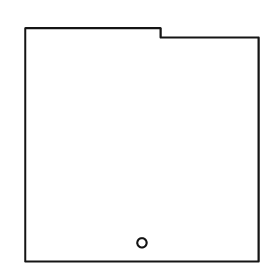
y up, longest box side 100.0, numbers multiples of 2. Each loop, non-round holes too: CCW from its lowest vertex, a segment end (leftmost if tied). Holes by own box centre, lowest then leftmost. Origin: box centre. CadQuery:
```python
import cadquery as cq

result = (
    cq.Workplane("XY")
    .moveTo(-50.0, -50.0)
    .lineTo(50.0, -50.0)
    .lineTo(50.0, 46.0)
    .lineTo(8.0, 46.0)
    .lineTo(8.0, 50.0)
    .lineTo(-50.0, 50.0)
    .close()
    .moveTo(0.0, -42.0)
    .circle(2.0)
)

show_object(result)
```